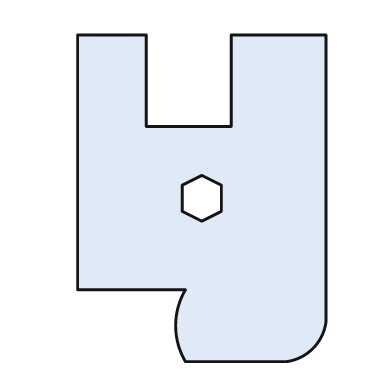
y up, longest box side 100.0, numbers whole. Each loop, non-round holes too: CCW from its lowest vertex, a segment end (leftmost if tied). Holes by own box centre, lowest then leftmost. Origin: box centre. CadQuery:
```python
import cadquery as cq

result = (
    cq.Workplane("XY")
    .moveTo(-5.0, -50.0)
    .lineTo(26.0, -50.0)
    .threePointArc((34.0, -46.0), (38.0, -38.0))
    .lineTo(38.0, 50.0)
    .lineTo(9.0, 50.0)
    .lineTo(9.0, 22.0)
    .lineTo(-17.0, 22.0)
    .lineTo(-17.0, 50.0)
    .lineTo(-38.0, 50.0)
    .lineTo(-38.0, -28.0)
    .lineTo(-5.0, -28.0)
    .threePointArc((-8.0, -39.0), (-5.0, -50.0))
    .close()
    .moveTo(0.0, -7.0)
    .lineTo(6.0, -4.0)
    .lineTo(6.0, 4.0)
    .lineTo(0.0, 7.0)
    .lineTo(-6.0, 4.0)
    .lineTo(-6.0, -4.0)
    .close()
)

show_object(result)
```